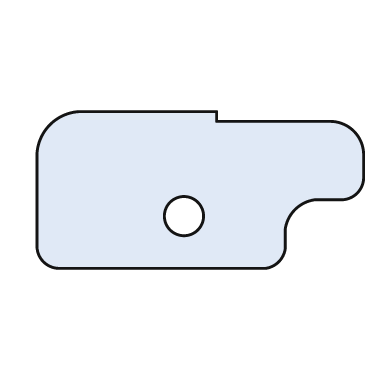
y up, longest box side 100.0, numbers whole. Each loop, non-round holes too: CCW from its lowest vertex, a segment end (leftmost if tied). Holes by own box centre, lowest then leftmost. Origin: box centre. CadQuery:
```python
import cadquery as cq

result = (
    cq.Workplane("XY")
    .moveTo(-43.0, -24.0)
    .lineTo(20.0, -24.0)
    .threePointArc((24.0, -22.0), (26.0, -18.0))
    .lineTo(26.0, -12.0)
    .threePointArc((29.0, -6.0), (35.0, -3.0))
    .lineTo(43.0, -3.0)
    .threePointArc((48.0, -1.0), (50.0, 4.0))
    .lineTo(50.0, 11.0)
    .threePointArc((47.0, 18.0), (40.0, 21.0))
    .lineTo(5.0, 21.0)
    .lineTo(5.0, 24.0)
    .lineTo(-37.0, 24.0)
    .threePointArc((-46.0, 20.0), (-50.0, 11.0))
    .lineTo(-50.0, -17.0)
    .threePointArc((-48.0, -22.0), (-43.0, -24.0))
    .close()
    .moveTo(-5.0, -8.0)
    .circle(6.0)
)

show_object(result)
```